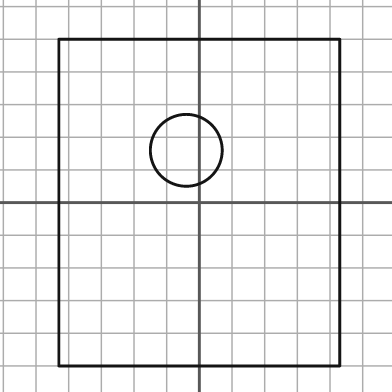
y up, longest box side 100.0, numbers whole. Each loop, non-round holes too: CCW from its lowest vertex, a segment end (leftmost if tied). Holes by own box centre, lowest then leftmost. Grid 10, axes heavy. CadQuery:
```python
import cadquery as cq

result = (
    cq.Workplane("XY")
    .moveTo(-43.0, -50.0)
    .lineTo(43.0, -50.0)
    .lineTo(43.0, 50.0)
    .lineTo(-43.0, 50.0)
    .close()
    .moveTo(-4.0, 16.0)
    .circle(11.0)
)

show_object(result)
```